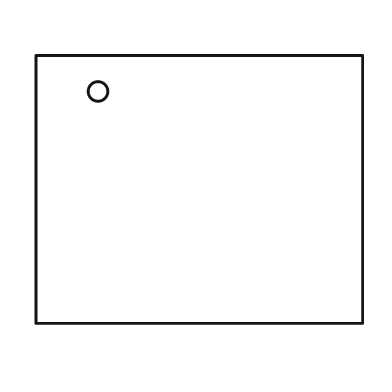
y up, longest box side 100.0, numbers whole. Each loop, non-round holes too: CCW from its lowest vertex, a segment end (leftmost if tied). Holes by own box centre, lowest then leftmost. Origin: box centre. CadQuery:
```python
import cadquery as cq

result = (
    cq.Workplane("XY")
    .moveTo(-50.0, -41.0)
    .lineTo(50.0, -41.0)
    .lineTo(50.0, 41.0)
    .lineTo(-50.0, 41.0)
    .close()
    .moveTo(-31.0, 30.0)
    .circle(3.0)
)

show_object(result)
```